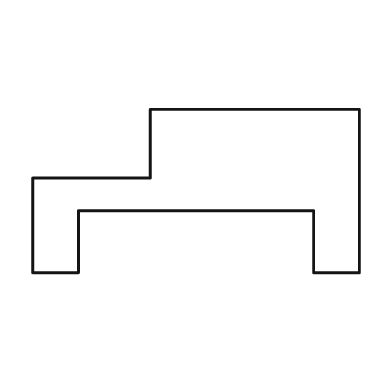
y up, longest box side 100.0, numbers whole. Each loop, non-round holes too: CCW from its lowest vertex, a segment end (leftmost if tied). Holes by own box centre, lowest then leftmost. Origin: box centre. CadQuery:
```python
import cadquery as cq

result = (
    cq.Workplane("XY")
    .moveTo(-50.0, -25.0)
    .lineTo(-36.0, -25.0)
    .lineTo(-36.0, -6.0)
    .lineTo(36.0, -6.0)
    .lineTo(36.0, -25.0)
    .lineTo(50.0, -25.0)
    .lineTo(50.0, 25.0)
    .lineTo(-14.0, 25.0)
    .lineTo(-14.0, 4.0)
    .lineTo(-50.0, 4.0)
    .close()
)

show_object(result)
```